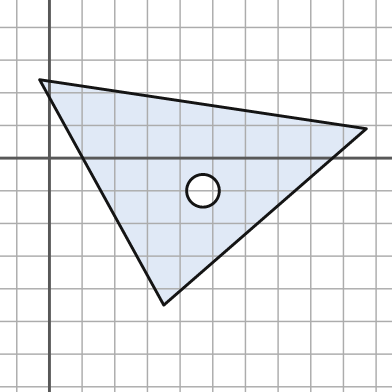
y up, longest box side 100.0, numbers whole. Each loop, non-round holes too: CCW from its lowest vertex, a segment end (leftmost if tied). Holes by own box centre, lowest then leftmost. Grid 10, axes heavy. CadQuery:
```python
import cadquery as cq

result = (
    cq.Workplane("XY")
    .moveTo(35.0, -45.0)
    .lineTo(97.0, 9.0)
    .lineTo(-3.0, 24.0)
    .close()
    .moveTo(47.0, -10.0)
    .circle(5.0)
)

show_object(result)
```